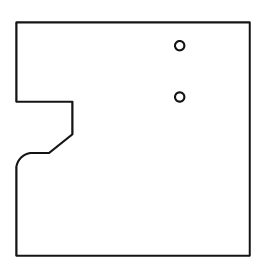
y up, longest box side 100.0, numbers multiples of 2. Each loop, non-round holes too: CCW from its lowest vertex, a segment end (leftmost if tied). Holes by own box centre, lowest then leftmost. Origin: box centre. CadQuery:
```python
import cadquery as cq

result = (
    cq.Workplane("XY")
    .moveTo(-50.0, -50.0)
    .lineTo(50.0, -50.0)
    .lineTo(50.0, 50.0)
    .lineTo(-50.0, 50.0)
    .lineTo(-50.0, 16.0)
    .lineTo(-26.0, 16.0)
    .lineTo(-26.0, 2.0)
    .lineTo(-36.0, -6.0)
    .lineTo(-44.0, -6.0)
    .threePointArc((-48.0, -8.0), (-50.0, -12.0))
    .close()
    .moveTo(20.0, 18.0)
    .circle(2.0)
    .moveTo(20.0, 40.0)
    .circle(2.0)
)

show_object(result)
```